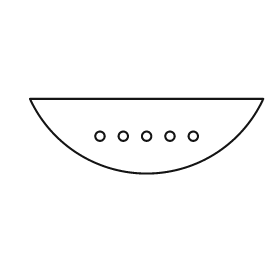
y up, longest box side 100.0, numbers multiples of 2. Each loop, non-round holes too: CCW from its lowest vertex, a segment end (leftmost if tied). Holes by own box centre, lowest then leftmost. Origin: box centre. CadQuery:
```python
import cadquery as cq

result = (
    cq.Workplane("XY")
    .moveTo(-50.0, 16.0)
    .threePointArc((0.0, -16.0), (50.0, 16.0))
    .close()
    .moveTo(-20.0, 0.0)
    .circle(2.0)
    .moveTo(-10.0, 0.0)
    .circle(2.0)
    .moveTo(0.0, 0.0)
    .circle(2.0)
    .moveTo(10.0, 0.0)
    .circle(2.0)
    .moveTo(20.0, 0.0)
    .circle(2.0)
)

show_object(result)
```